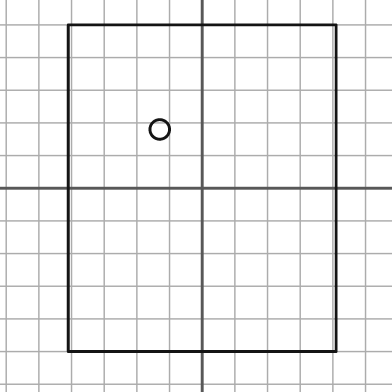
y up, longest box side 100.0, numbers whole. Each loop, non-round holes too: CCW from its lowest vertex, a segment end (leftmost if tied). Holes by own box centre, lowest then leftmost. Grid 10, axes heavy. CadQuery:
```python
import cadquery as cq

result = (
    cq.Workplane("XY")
    .moveTo(-41.0, -50.0)
    .lineTo(41.0, -50.0)
    .lineTo(41.0, 50.0)
    .lineTo(-41.0, 50.0)
    .close()
    .moveTo(-13.0, 18.0)
    .circle(3.0)
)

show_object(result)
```